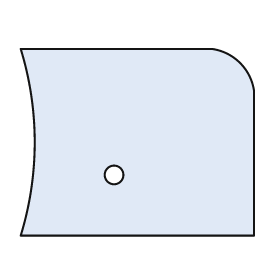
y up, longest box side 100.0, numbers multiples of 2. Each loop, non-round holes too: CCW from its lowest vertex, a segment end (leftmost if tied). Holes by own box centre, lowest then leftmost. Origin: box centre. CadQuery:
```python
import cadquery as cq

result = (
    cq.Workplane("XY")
    .moveTo(-50.0, -40.0)
    .lineTo(50.0, -40.0)
    .lineTo(50.0, 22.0)
    .threePointArc((44.0, 34.0), (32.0, 40.0))
    .lineTo(-50.0, 40.0)
    .threePointArc((-44.0, 0.0), (-50.0, -40.0))
    .close()
    .moveTo(-10.0, -14.0)
    .circle(4.0)
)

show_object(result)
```